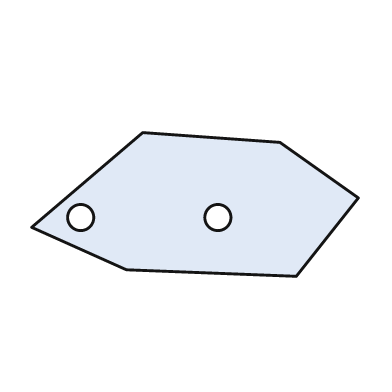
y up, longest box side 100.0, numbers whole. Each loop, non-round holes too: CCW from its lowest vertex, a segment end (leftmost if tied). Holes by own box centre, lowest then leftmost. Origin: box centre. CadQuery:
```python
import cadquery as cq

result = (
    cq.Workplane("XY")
    .moveTo(31.0, -22.0)
    .lineTo(50.0, 2.0)
    .lineTo(26.0, 19.0)
    .lineTo(-16.0, 22.0)
    .lineTo(-50.0, -7.0)
    .lineTo(-21.0, -20.0)
    .close()
    .moveTo(-35.0, -4.0)
    .circle(4.0)
    .moveTo(7.0, -4.0)
    .circle(4.0)
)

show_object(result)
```